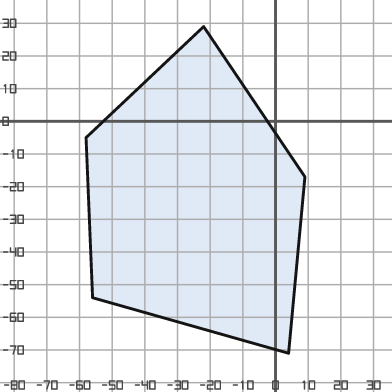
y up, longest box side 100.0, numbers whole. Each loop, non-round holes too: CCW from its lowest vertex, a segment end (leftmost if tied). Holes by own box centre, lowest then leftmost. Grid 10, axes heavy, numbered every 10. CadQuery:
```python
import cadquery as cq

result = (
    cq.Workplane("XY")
    .moveTo(4.0, -71.0)
    .lineTo(9.0, -17.0)
    .lineTo(-22.0, 29.0)
    .lineTo(-58.0, -5.0)
    .lineTo(-56.0, -54.0)
    .close()
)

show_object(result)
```